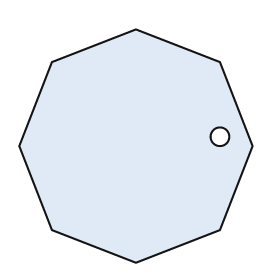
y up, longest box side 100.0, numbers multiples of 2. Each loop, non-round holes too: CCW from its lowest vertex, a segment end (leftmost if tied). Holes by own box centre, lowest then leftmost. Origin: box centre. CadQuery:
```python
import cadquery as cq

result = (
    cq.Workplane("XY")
    .moveTo(0.0, -50.0)
    .lineTo(36.0, -36.0)
    .lineTo(50.0, 0.0)
    .lineTo(36.0, 36.0)
    .lineTo(0.0, 50.0)
    .lineTo(-36.0, 36.0)
    .lineTo(-50.0, 0.0)
    .lineTo(-36.0, -36.0)
    .close()
    .moveTo(36.0, 4.0)
    .circle(4.0)
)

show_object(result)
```